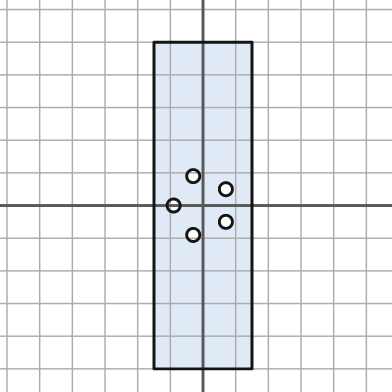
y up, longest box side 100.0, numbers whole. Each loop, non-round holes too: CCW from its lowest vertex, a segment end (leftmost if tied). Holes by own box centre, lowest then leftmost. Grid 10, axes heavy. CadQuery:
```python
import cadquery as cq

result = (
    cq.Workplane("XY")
    .moveTo(-15.0, -50.0)
    .lineTo(15.0, -50.0)
    .lineTo(15.0, 50.0)
    .lineTo(-15.0, 50.0)
    .close()
    .moveTo(-3.0, -9.0)
    .circle(2.0)
    .moveTo(7.0, -5.0)
    .circle(2.0)
    .moveTo(-9.0, 0.0)
    .circle(2.0)
    .moveTo(7.0, 5.0)
    .circle(2.0)
    .moveTo(-3.0, 9.0)
    .circle(2.0)
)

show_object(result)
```